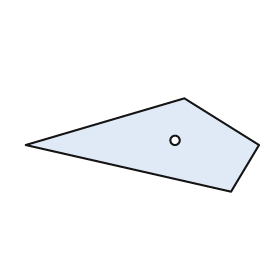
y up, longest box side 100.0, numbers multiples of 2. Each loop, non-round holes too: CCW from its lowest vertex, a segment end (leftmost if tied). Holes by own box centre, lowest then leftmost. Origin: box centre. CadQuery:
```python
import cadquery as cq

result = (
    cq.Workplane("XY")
    .moveTo(38.0, -20.0)
    .lineTo(50.0, 0.0)
    .lineTo(18.0, 20.0)
    .lineTo(-50.0, 0.0)
    .close()
    .moveTo(14.0, 2.0)
    .circle(2.0)
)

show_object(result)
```